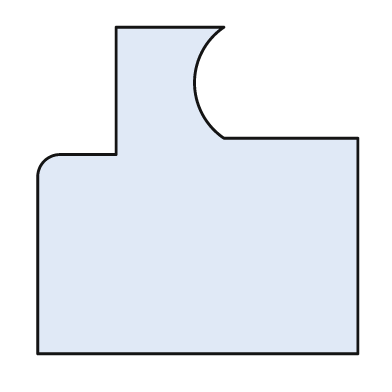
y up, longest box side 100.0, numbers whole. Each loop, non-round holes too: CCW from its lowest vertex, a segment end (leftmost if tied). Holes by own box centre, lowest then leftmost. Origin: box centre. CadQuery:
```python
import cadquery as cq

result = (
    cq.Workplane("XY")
    .moveTo(-49.0, -50.0)
    .lineTo(49.0, -50.0)
    .lineTo(49.0, 16.0)
    .lineTo(8.0, 16.0)
    .threePointArc((-1.0, 33.0), (8.0, 50.0))
    .lineTo(-25.0, 50.0)
    .lineTo(-25.0, 11.0)
    .lineTo(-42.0, 11.0)
    .threePointArc((-47.0, 9.0), (-49.0, 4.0))
    .close()
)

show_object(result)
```